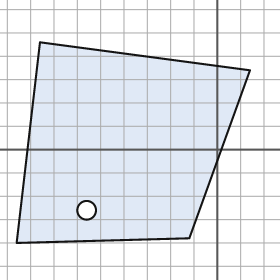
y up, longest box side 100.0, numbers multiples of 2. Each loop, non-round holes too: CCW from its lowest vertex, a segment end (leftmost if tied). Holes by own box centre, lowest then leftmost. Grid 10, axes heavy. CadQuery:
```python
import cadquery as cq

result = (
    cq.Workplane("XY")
    .moveTo(-86.0, -40.0)
    .lineTo(-12.0, -38.0)
    .lineTo(14.0, 34.0)
    .lineTo(-76.0, 46.0)
    .close()
    .moveTo(-56.0, -26.0)
    .circle(4.0)
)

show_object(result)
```